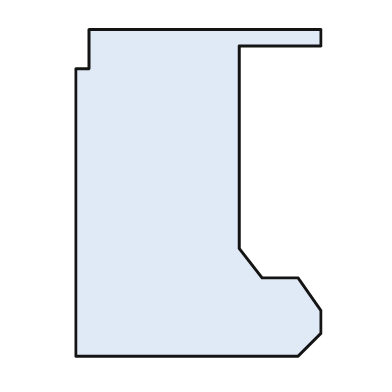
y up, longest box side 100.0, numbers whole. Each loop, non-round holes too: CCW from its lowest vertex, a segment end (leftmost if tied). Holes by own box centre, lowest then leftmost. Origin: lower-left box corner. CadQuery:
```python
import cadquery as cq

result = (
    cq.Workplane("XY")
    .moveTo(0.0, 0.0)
    .lineTo(68.0, 0.0)
    .lineTo(75.0, 7.0)
    .lineTo(75.0, 14.0)
    .lineTo(68.0, 24.0)
    .lineTo(57.0, 24.0)
    .lineTo(50.0, 33.0)
    .lineTo(50.0, 95.0)
    .lineTo(75.0, 95.0)
    .lineTo(75.0, 100.0)
    .lineTo(4.0, 100.0)
    .lineTo(4.0, 88.0)
    .lineTo(0.0, 88.0)
    .close()
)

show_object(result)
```